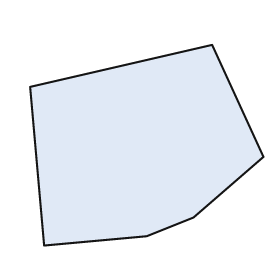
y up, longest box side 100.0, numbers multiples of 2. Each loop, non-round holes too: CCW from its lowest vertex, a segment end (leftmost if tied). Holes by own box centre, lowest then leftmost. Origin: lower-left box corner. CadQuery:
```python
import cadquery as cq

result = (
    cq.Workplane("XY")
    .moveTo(6.0, 0.0)
    .lineTo(50.0, 4.0)
    .lineTo(70.0, 12.0)
    .lineTo(100.0, 38.0)
    .lineTo(78.0, 86.0)
    .lineTo(0.0, 68.0)
    .close()
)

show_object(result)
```